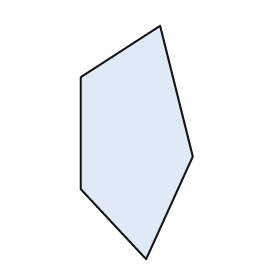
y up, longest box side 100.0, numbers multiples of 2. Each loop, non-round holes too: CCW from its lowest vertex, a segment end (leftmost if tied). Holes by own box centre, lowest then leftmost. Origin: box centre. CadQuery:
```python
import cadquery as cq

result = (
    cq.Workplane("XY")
    .moveTo(4.0, -50.0)
    .lineTo(24.0, -6.0)
    .lineTo(10.0, 50.0)
    .lineTo(-24.0, 28.0)
    .lineTo(-24.0, -20.0)
    .close()
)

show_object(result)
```